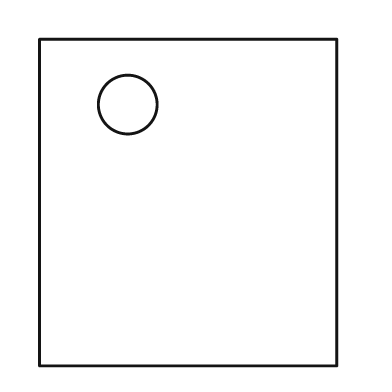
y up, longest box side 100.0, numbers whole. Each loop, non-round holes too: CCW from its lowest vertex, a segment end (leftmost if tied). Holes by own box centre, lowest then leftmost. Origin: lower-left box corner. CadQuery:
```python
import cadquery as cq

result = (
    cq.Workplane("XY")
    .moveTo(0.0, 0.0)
    .lineTo(91.0, 0.0)
    .lineTo(91.0, 100.0)
    .lineTo(0.0, 100.0)
    .close()
    .moveTo(27.0, 80.0)
    .circle(9.0)
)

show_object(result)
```